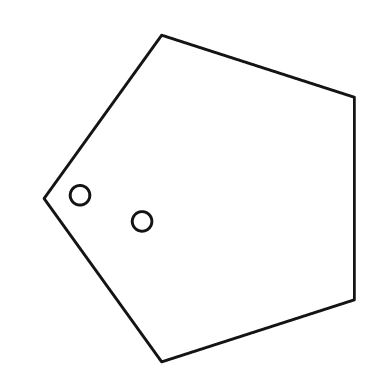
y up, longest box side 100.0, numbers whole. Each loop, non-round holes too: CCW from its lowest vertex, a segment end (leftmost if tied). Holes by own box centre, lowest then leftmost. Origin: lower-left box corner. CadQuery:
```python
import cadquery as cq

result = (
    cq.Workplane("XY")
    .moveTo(36.0, 0.0)
    .lineTo(95.0, 19.0)
    .lineTo(95.0, 81.0)
    .lineTo(36.0, 100.0)
    .lineTo(0.0, 50.0)
    .close()
    .moveTo(30.0, 43.0)
    .circle(3.0)
    .moveTo(11.0, 51.0)
    .circle(3.0)
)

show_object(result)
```